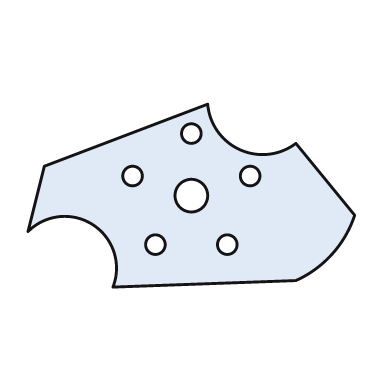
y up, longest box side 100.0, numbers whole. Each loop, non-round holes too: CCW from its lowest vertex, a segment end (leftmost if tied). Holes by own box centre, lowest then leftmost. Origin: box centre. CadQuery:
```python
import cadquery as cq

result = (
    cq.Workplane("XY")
    .moveTo(-24.0, -28.0)
    .lineTo(32.0, -26.0)
    .threePointArc((43.0, -18.0), (50.0, -6.0))
    .lineTo(32.0, 16.0)
    .threePointArc((15.0, 14.0), (5.0, 28.0))
    .lineTo(-45.0, 9.0)
    .lineTo(-50.0, -11.0)
    .threePointArc((-30.0, -9.0), (-24.0, -28.0))
    .close()
    .moveTo(-11.0, -15.0)
    .circle(3.0)
    .moveTo(11.0, -15.0)
    .circle(3.0)
    .moveTo(0.0, 0.0)
    .circle(5.0)
    .moveTo(-18.0, 6.0)
    .circle(3.0)
    .moveTo(18.0, 6.0)
    .circle(3.0)
    .moveTo(0.0, 19.0)
    .circle(3.0)
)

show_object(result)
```